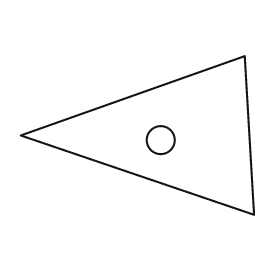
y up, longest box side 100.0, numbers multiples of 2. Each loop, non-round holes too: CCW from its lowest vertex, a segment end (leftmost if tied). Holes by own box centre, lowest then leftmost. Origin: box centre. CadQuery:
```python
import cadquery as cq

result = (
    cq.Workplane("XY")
    .moveTo(50.0, -34.0)
    .lineTo(46.0, 34.0)
    .lineTo(-50.0, 0.0)
    .close()
    .moveTo(10.0, -2.0)
    .circle(6.0)
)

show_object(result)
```